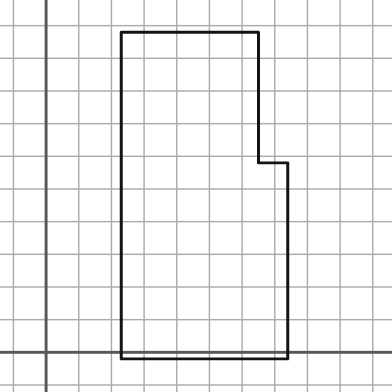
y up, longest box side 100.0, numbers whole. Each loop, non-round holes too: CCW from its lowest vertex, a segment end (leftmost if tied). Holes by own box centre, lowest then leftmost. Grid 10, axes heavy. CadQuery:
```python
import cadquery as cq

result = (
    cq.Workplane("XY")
    .moveTo(23.0, -2.0)
    .lineTo(74.0, -2.0)
    .lineTo(74.0, 58.0)
    .lineTo(65.0, 58.0)
    .lineTo(65.0, 98.0)
    .lineTo(23.0, 98.0)
    .close()
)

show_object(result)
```